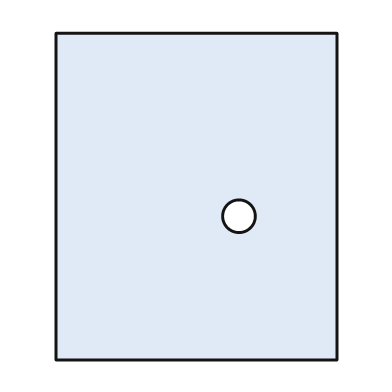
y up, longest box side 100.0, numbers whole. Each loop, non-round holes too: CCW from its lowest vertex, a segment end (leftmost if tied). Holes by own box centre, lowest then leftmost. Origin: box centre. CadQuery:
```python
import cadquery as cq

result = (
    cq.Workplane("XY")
    .moveTo(-43.0, -50.0)
    .lineTo(43.0, -50.0)
    .lineTo(43.0, 50.0)
    .lineTo(-43.0, 50.0)
    .close()
    .moveTo(13.0, -6.0)
    .circle(5.0)
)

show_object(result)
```